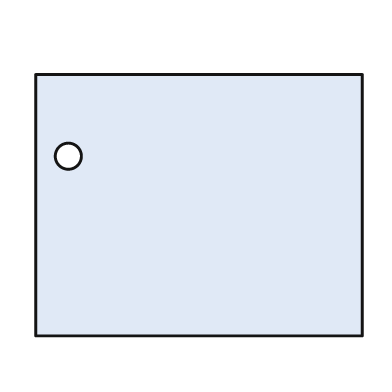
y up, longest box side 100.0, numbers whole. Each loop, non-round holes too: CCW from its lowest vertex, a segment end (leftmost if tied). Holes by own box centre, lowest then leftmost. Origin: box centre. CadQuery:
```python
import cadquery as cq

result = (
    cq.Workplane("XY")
    .moveTo(-50.0, -40.0)
    .lineTo(50.0, -40.0)
    .lineTo(50.0, 40.0)
    .lineTo(-50.0, 40.0)
    .close()
    .moveTo(-40.0, 15.0)
    .circle(4.0)
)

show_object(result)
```